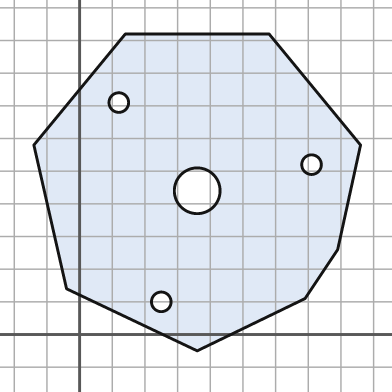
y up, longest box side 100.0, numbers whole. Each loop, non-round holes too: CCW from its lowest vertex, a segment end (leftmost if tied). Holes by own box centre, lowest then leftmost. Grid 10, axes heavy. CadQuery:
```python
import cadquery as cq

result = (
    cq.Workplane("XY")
    .moveTo(36.0, -5.0)
    .lineTo(69.0, 11.0)
    .lineTo(79.0, 26.0)
    .lineTo(86.0, 58.0)
    .lineTo(58.0, 92.0)
    .lineTo(14.0, 92.0)
    .lineTo(-14.0, 58.0)
    .lineTo(-4.0, 14.0)
    .close()
    .moveTo(25.0, 10.0)
    .circle(3.0)
    .moveTo(36.0, 44.0)
    .circle(7.0)
    .moveTo(71.0, 52.0)
    .circle(3.0)
    .moveTo(12.0, 71.0)
    .circle(3.0)
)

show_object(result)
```